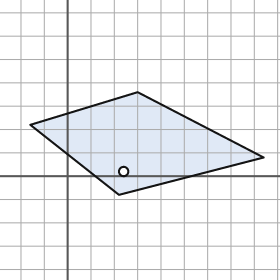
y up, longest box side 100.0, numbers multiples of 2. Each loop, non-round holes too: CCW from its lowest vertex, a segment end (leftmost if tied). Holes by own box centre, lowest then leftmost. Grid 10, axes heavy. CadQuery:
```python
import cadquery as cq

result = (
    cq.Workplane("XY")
    .moveTo(22.0, -8.0)
    .lineTo(84.0, 8.0)
    .lineTo(30.0, 36.0)
    .lineTo(-16.0, 22.0)
    .close()
    .moveTo(24.0, 2.0)
    .circle(2.0)
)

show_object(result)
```